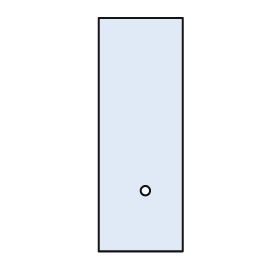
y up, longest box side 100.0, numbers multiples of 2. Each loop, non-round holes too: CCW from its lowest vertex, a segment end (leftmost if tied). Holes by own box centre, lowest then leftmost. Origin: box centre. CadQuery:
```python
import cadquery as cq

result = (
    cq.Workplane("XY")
    .moveTo(-18.0, -50.0)
    .lineTo(18.0, -50.0)
    .lineTo(18.0, 50.0)
    .lineTo(-18.0, 50.0)
    .close()
    .moveTo(2.0, -24.0)
    .circle(2.0)
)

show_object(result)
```